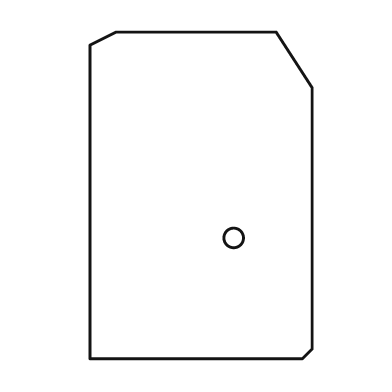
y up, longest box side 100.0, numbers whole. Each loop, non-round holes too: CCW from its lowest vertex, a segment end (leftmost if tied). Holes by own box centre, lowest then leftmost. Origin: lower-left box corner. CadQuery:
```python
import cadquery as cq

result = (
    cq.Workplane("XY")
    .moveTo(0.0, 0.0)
    .lineTo(65.0, 0.0)
    .lineTo(68.0, 3.0)
    .lineTo(68.0, 83.0)
    .lineTo(57.0, 100.0)
    .lineTo(8.0, 100.0)
    .lineTo(0.0, 96.0)
    .close()
    .moveTo(44.0, 37.0)
    .circle(3.0)
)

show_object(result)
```